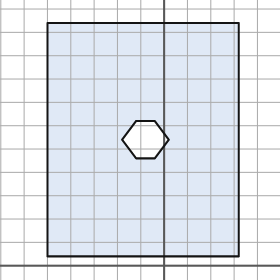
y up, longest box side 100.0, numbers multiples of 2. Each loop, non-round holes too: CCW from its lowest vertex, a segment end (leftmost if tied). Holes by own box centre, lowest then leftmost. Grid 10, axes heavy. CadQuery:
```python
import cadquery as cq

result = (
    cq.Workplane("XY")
    .moveTo(-50.0, 4.0)
    .lineTo(32.0, 4.0)
    .lineTo(32.0, 104.0)
    .lineTo(-50.0, 104.0)
    .close()
    .moveTo(-12.0, 46.0)
    .lineTo(-4.0, 46.0)
    .lineTo(2.0, 54.0)
    .lineTo(-4.0, 62.0)
    .lineTo(-12.0, 62.0)
    .lineTo(-18.0, 54.0)
    .close()
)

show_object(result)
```